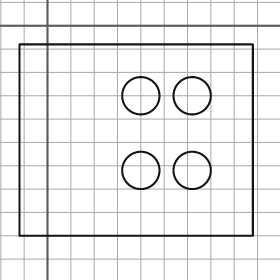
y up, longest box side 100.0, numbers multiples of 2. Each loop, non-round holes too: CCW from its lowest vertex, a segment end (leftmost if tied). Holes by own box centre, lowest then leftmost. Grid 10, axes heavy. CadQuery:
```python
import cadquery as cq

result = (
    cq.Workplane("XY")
    .moveTo(-12.0, -90.0)
    .lineTo(88.0, -90.0)
    .lineTo(88.0, -8.0)
    .lineTo(-12.0, -8.0)
    .close()
    .moveTo(40.0, -62.0)
    .circle(8.0)
    .moveTo(62.0, -62.0)
    .circle(8.0)
    .moveTo(40.0, -30.0)
    .circle(8.0)
    .moveTo(62.0, -30.0)
    .circle(8.0)
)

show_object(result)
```